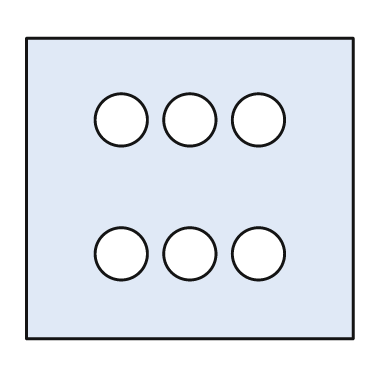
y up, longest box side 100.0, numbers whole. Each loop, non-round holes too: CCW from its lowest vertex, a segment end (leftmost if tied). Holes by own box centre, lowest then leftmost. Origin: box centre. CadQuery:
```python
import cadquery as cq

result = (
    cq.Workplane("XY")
    .moveTo(-50.0, -46.0)
    .lineTo(50.0, -46.0)
    .lineTo(50.0, 46.0)
    .lineTo(-50.0, 46.0)
    .close()
    .moveTo(-21.0, -20.0)
    .circle(8.0)
    .moveTo(0.0, -20.0)
    .circle(8.0)
    .moveTo(21.0, -20.0)
    .circle(8.0)
    .moveTo(-21.0, 21.0)
    .circle(8.0)
    .moveTo(0.0, 21.0)
    .circle(8.0)
    .moveTo(21.0, 21.0)
    .circle(8.0)
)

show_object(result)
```